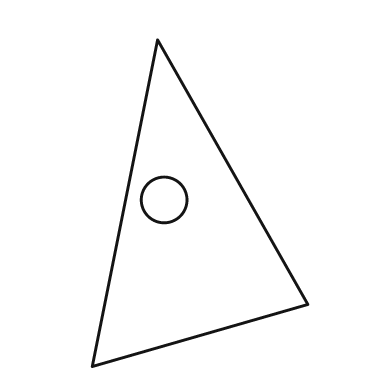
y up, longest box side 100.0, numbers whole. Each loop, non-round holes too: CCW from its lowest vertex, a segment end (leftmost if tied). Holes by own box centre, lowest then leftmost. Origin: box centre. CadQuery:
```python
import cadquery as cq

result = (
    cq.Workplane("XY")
    .moveTo(-33.0, -50.0)
    .lineTo(33.0, -31.0)
    .lineTo(-13.0, 50.0)
    .close()
    .moveTo(-11.0, 1.0)
    .circle(7.0)
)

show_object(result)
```